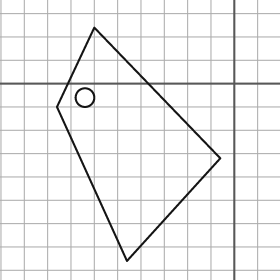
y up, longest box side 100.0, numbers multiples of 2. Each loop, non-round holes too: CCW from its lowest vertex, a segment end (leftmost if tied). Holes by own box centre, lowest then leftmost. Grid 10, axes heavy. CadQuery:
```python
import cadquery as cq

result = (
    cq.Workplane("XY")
    .moveTo(-46.0, -76.0)
    .lineTo(-6.0, -32.0)
    .lineTo(-60.0, 24.0)
    .lineTo(-76.0, -10.0)
    .close()
    .moveTo(-64.0, -6.0)
    .circle(4.0)
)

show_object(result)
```